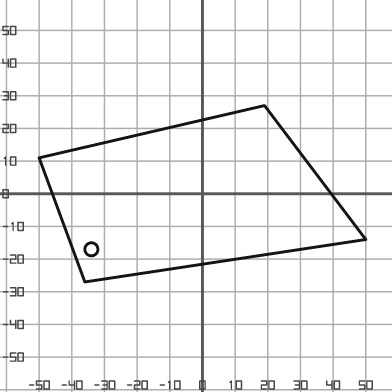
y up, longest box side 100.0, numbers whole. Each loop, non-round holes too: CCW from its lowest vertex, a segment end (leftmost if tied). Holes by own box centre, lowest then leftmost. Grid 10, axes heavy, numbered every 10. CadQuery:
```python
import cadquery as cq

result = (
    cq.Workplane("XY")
    .moveTo(-36.0, -27.0)
    .lineTo(50.0, -14.0)
    .lineTo(19.0, 27.0)
    .lineTo(-50.0, 11.0)
    .close()
    .moveTo(-34.0, -17.0)
    .circle(2.0)
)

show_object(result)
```